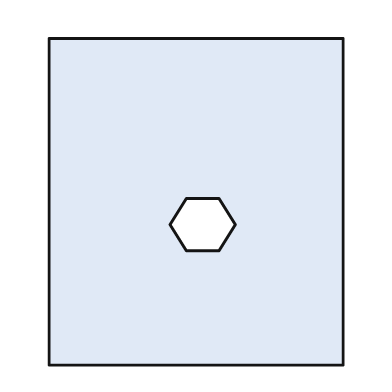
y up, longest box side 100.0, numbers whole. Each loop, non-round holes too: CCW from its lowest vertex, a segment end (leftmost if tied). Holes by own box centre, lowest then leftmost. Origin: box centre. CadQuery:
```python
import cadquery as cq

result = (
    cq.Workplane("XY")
    .moveTo(-45.0, -50.0)
    .lineTo(45.0, -50.0)
    .lineTo(45.0, 50.0)
    .lineTo(-45.0, 50.0)
    .close()
    .moveTo(-3.0, -15.0)
    .lineTo(7.0, -15.0)
    .lineTo(12.0, -7.0)
    .lineTo(7.0, 1.0)
    .lineTo(-3.0, 1.0)
    .lineTo(-8.0, -7.0)
    .close()
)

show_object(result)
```